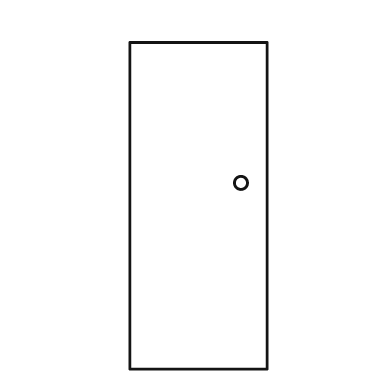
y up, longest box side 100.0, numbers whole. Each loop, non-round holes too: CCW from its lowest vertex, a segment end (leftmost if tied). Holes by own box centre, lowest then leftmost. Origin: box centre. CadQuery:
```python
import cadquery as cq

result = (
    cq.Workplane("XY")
    .moveTo(-21.0, -50.0)
    .lineTo(21.0, -50.0)
    .lineTo(21.0, 50.0)
    .lineTo(-21.0, 50.0)
    .close()
    .moveTo(13.0, 7.0)
    .circle(2.0)
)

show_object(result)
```